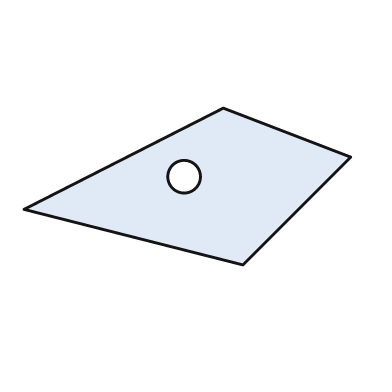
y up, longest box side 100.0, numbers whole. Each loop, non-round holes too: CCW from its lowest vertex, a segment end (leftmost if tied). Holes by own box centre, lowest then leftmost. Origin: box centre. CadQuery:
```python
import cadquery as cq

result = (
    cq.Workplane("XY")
    .moveTo(17.0, -24.0)
    .lineTo(50.0, 9.0)
    .lineTo(11.0, 24.0)
    .lineTo(-50.0, -7.0)
    .close()
    .moveTo(-1.0, 3.0)
    .circle(5.0)
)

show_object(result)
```